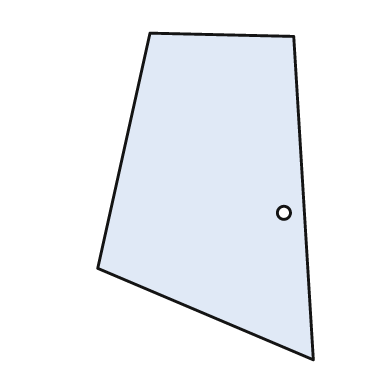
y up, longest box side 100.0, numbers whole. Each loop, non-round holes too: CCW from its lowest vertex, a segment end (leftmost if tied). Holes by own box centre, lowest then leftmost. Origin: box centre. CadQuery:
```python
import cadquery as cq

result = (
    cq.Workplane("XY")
    .moveTo(33.0, -50.0)
    .lineTo(27.0, 49.0)
    .lineTo(-17.0, 50.0)
    .lineTo(-33.0, -22.0)
    .close()
    .moveTo(24.0, -5.0)
    .circle(2.0)
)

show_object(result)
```